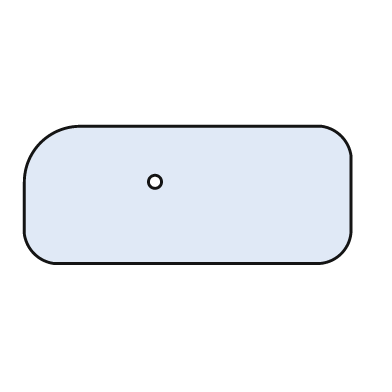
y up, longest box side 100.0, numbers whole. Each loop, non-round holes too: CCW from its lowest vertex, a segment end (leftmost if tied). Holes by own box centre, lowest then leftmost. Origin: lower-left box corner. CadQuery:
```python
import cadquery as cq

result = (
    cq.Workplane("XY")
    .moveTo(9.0, 0.0)
    .lineTo(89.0, 0.0)
    .threePointArc((97.0, 3.0), (100.0, 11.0))
    .lineTo(100.0, 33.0)
    .threePointArc((97.0, 39.0), (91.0, 42.0))
    .lineTo(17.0, 42.0)
    .threePointArc((5.0, 37.0), (0.0, 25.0))
    .lineTo(0.0, 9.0)
    .threePointArc((3.0, 3.0), (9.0, 0.0))
    .close()
    .moveTo(40.0, 25.0)
    .circle(2.0)
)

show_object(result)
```